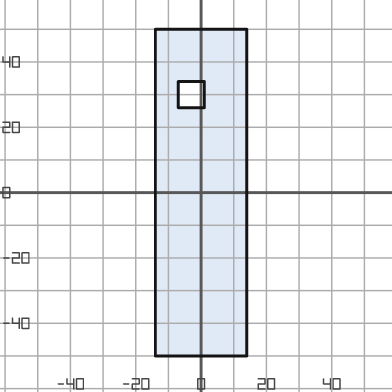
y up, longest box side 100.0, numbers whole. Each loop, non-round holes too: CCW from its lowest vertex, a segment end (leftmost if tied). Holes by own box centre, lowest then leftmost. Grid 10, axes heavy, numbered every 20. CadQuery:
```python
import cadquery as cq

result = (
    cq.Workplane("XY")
    .moveTo(-14.0, -50.0)
    .lineTo(14.0, -50.0)
    .lineTo(14.0, 50.0)
    .lineTo(-14.0, 50.0)
    .close()
    .moveTo(-7.0, 26.0)
    .lineTo(1.0, 26.0)
    .lineTo(1.0, 34.0)
    .lineTo(-7.0, 34.0)
    .close()
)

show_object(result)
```